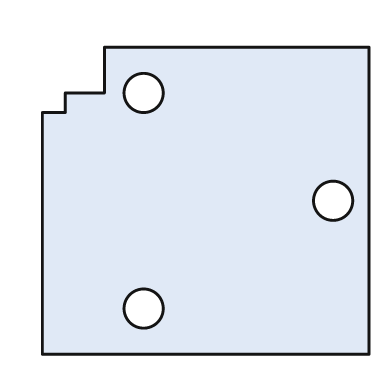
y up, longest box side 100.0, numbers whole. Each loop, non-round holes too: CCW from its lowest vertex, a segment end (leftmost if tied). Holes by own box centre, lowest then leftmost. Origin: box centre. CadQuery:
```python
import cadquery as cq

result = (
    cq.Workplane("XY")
    .moveTo(-50.0, -47.0)
    .lineTo(50.0, -47.0)
    .lineTo(50.0, 47.0)
    .lineTo(-31.0, 47.0)
    .lineTo(-31.0, 33.0)
    .lineTo(-43.0, 33.0)
    .lineTo(-43.0, 27.0)
    .lineTo(-50.0, 27.0)
    .close()
    .moveTo(-19.0, -33.0)
    .circle(6.0)
    .moveTo(39.0, 0.0)
    .circle(6.0)
    .moveTo(-19.0, 33.0)
    .circle(6.0)
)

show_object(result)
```